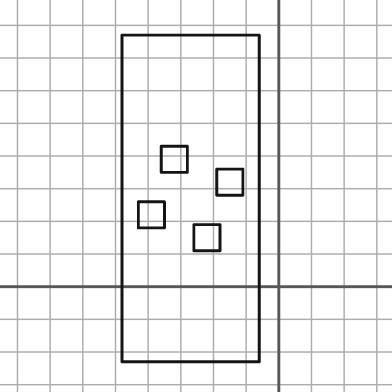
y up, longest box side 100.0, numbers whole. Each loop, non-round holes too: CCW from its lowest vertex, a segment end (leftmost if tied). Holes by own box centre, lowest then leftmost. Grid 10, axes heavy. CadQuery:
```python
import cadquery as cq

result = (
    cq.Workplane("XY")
    .moveTo(-48.0, -23.0)
    .lineTo(-6.0, -23.0)
    .lineTo(-6.0, 77.0)
    .lineTo(-48.0, 77.0)
    .close()
    .moveTo(-26.0, 11.0)
    .lineTo(-18.0, 11.0)
    .lineTo(-18.0, 19.0)
    .lineTo(-26.0, 19.0)
    .close()
    .moveTo(-43.0, 18.0)
    .lineTo(-35.0, 18.0)
    .lineTo(-35.0, 26.0)
    .lineTo(-43.0, 26.0)
    .close()
    .moveTo(-19.0, 28.0)
    .lineTo(-11.0, 28.0)
    .lineTo(-11.0, 36.0)
    .lineTo(-19.0, 36.0)
    .close()
    .moveTo(-36.0, 35.0)
    .lineTo(-28.0, 35.0)
    .lineTo(-28.0, 43.0)
    .lineTo(-36.0, 43.0)
    .close()
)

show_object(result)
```